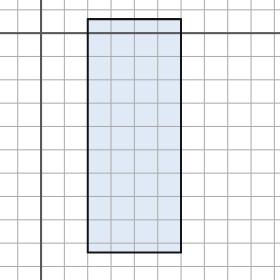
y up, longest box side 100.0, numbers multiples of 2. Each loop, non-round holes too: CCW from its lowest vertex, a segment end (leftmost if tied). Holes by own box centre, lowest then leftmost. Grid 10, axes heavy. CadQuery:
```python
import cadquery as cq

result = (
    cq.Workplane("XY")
    .moveTo(20.0, -94.0)
    .lineTo(60.0, -94.0)
    .lineTo(60.0, 6.0)
    .lineTo(20.0, 6.0)
    .close()
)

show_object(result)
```